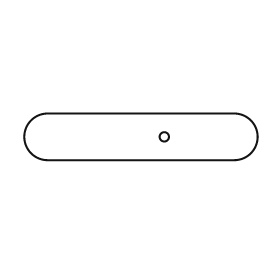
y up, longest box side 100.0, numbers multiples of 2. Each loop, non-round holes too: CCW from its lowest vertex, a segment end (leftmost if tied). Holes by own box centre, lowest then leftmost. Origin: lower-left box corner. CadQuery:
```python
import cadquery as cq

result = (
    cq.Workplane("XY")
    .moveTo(10.0, 0.0)
    .lineTo(90.0, 0.0)
    .threePointArc((100.0, 10.0), (90.0, 20.0))
    .lineTo(10.0, 20.0)
    .threePointArc((0.0, 10.0), (10.0, 0.0))
    .close()
    .moveTo(60.0, 10.0)
    .circle(2.0)
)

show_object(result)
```